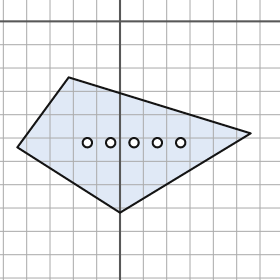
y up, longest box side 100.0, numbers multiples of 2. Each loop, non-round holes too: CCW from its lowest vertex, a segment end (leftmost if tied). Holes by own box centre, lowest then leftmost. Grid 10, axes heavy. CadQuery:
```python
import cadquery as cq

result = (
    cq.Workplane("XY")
    .moveTo(0.0, -82.0)
    .lineTo(56.0, -48.0)
    .lineTo(-22.0, -24.0)
    .lineTo(-44.0, -54.0)
    .close()
    .moveTo(-14.0, -52.0)
    .circle(2.0)
    .moveTo(-4.0, -52.0)
    .circle(2.0)
    .moveTo(6.0, -52.0)
    .circle(2.0)
    .moveTo(16.0, -52.0)
    .circle(2.0)
    .moveTo(26.0, -52.0)
    .circle(2.0)
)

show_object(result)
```